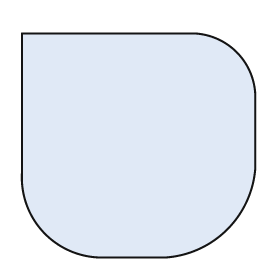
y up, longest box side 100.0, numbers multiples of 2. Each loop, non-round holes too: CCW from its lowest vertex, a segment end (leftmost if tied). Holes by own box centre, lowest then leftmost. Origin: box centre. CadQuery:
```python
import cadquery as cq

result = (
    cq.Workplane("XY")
    .moveTo(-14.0, -48.0)
    .lineTo(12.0, -48.0)
    .threePointArc((38.0, -36.0), (50.0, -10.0))
    .lineTo(50.0, 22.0)
    .threePointArc((42.0, 40.0), (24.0, 48.0))
    .lineTo(-50.0, 48.0)
    .lineTo(-50.0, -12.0)
    .threePointArc((-40.0, -38.0), (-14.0, -48.0))
    .close()
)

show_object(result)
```